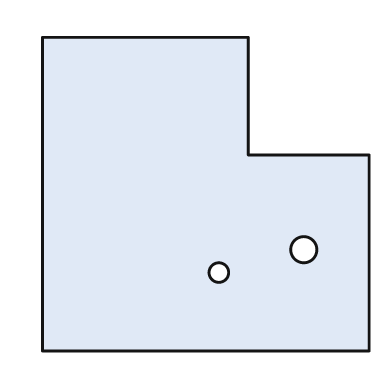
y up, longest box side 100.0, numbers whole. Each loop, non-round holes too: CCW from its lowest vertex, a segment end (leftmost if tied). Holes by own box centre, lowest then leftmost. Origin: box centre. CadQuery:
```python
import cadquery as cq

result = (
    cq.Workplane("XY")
    .moveTo(-50.0, -48.0)
    .lineTo(50.0, -48.0)
    .lineTo(50.0, 12.0)
    .lineTo(13.0, 12.0)
    .lineTo(13.0, 48.0)
    .lineTo(-50.0, 48.0)
    .close()
    .moveTo(4.0, -24.0)
    .circle(3.0)
    .moveTo(30.0, -17.0)
    .circle(4.0)
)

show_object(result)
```